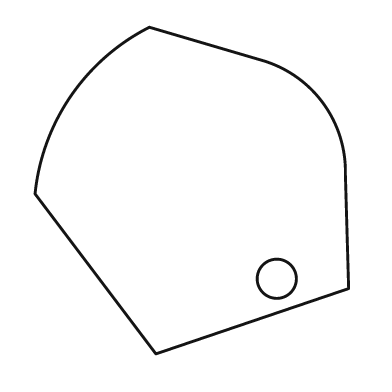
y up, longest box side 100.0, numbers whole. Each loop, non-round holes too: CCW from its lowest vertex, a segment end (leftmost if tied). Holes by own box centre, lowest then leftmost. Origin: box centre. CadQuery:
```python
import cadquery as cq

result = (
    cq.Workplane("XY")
    .moveTo(-11.0, -50.0)
    .lineTo(48.0, -30.0)
    .lineTo(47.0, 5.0)
    .threePointArc((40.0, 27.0), (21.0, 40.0))
    .lineTo(-13.0, 50.0)
    .threePointArc((-37.0, 29.0), (-48.0, -1.0))
    .close()
    .moveTo(26.0, -27.0)
    .circle(6.0)
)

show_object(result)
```